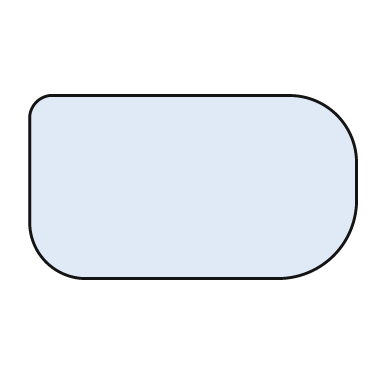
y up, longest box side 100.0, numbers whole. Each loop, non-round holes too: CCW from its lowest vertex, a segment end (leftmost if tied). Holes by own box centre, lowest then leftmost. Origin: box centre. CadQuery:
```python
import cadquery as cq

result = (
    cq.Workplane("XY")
    .moveTo(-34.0, -28.0)
    .lineTo(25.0, -28.0)
    .threePointArc((43.0, -21.0), (50.0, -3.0))
    .lineTo(50.0, 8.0)
    .threePointArc((44.0, 22.0), (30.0, 28.0))
    .lineTo(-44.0, 28.0)
    .threePointArc((-48.0, 26.0), (-50.0, 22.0))
    .lineTo(-50.0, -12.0)
    .threePointArc((-45.0, -23.0), (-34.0, -28.0))
    .close()
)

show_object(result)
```